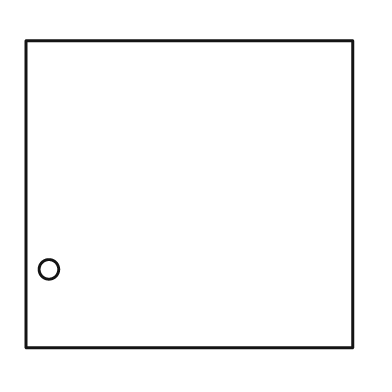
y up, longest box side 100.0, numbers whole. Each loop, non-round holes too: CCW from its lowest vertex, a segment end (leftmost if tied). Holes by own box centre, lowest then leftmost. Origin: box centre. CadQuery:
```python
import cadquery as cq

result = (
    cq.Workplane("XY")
    .moveTo(-50.0, -47.0)
    .lineTo(50.0, -47.0)
    .lineTo(50.0, 47.0)
    .lineTo(-50.0, 47.0)
    .close()
    .moveTo(-43.0, -23.0)
    .circle(3.0)
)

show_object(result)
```